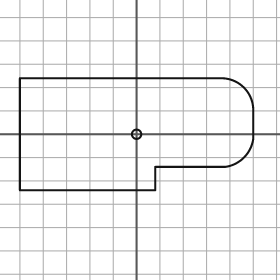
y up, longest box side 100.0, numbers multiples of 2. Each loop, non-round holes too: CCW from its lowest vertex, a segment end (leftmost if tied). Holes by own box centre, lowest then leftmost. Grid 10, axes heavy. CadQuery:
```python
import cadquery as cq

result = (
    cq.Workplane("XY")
    .moveTo(-50.0, -24.0)
    .lineTo(8.0, -24.0)
    .lineTo(8.0, -14.0)
    .lineTo(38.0, -14.0)
    .threePointArc((46.0, -10.0), (50.0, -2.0))
    .lineTo(50.0, 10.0)
    .threePointArc((46.0, 20.0), (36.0, 24.0))
    .lineTo(-50.0, 24.0)
    .close()
    .moveTo(0.0, 0.0)
    .circle(2.0)
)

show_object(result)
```